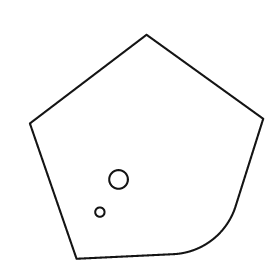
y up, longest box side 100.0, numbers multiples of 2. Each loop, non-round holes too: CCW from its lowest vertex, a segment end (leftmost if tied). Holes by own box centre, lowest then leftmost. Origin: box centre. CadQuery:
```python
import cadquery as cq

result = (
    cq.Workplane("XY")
    .moveTo(-30.0, -48.0)
    .lineTo(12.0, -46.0)
    .threePointArc((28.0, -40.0), (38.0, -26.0))
    .lineTo(50.0, 12.0)
    .lineTo(0.0, 48.0)
    .lineTo(-50.0, 10.0)
    .close()
    .moveTo(-20.0, -28.0)
    .circle(2.0)
    .moveTo(-12.0, -14.0)
    .circle(4.0)
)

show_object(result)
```